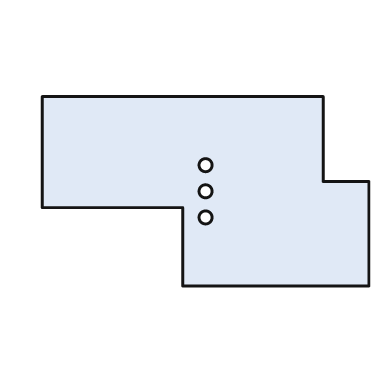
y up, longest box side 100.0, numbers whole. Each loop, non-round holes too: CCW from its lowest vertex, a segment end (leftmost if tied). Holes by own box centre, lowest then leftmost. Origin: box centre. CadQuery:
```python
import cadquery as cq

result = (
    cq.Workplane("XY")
    .moveTo(-7.0, -29.0)
    .lineTo(50.0, -29.0)
    .lineTo(50.0, 3.0)
    .lineTo(36.0, 3.0)
    .lineTo(36.0, 29.0)
    .lineTo(-50.0, 29.0)
    .lineTo(-50.0, -5.0)
    .lineTo(-7.0, -5.0)
    .close()
    .moveTo(0.0, -8.0)
    .circle(2.0)
    .moveTo(0.0, 0.0)
    .circle(2.0)
    .moveTo(0.0, 8.0)
    .circle(2.0)
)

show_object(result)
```